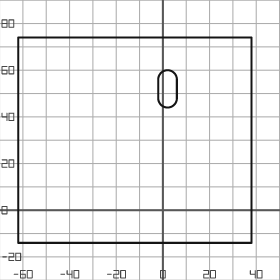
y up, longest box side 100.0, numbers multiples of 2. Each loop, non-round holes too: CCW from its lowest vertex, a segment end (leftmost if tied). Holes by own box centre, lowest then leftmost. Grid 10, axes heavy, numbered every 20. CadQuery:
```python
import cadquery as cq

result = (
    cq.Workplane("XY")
    .moveTo(-62.0, -14.0)
    .lineTo(38.0, -14.0)
    .lineTo(38.0, 74.0)
    .lineTo(-62.0, 74.0)
    .close()
    .moveTo(-2.0, 48.0)
    .threePointArc((2.0, 44.0), (6.0, 48.0))
    .lineTo(6.0, 56.0)
    .threePointArc((2.0, 60.0), (-2.0, 56.0))
    .close()
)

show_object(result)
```